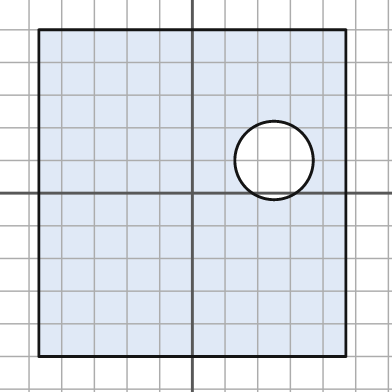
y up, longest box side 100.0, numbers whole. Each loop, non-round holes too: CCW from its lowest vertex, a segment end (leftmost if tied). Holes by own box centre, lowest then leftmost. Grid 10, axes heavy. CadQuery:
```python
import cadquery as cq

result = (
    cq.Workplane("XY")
    .moveTo(-47.0, -50.0)
    .lineTo(47.0, -50.0)
    .lineTo(47.0, 50.0)
    .lineTo(-47.0, 50.0)
    .close()
    .moveTo(25.0, 10.0)
    .circle(12.0)
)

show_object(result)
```